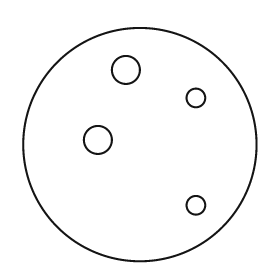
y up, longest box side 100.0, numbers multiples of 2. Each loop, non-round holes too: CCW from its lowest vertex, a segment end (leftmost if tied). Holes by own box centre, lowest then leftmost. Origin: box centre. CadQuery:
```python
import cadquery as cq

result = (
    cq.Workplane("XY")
    .moveTo(0.0, 0.0)
    .circle(50.0)
    .moveTo(24.0, -26.0)
    .circle(4.0)
    .moveTo(-18.0, 2.0)
    .circle(6.0)
    .moveTo(24.0, 20.0)
    .circle(4.0)
    .moveTo(-6.0, 32.0)
    .circle(6.0)
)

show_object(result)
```